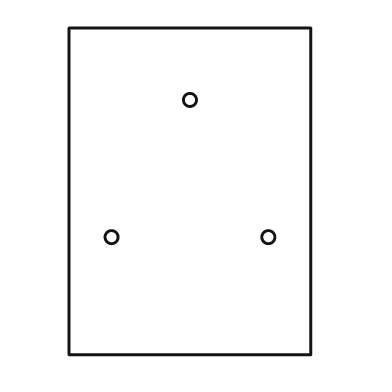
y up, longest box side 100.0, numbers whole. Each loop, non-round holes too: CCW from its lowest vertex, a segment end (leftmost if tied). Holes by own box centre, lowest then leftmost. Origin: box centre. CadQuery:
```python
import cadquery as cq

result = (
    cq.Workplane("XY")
    .moveTo(-37.0, -50.0)
    .lineTo(37.0, -50.0)
    .lineTo(37.0, 50.0)
    .lineTo(-37.0, 50.0)
    .close()
    .moveTo(-24.0, -14.0)
    .circle(2.0)
    .moveTo(24.0, -14.0)
    .circle(2.0)
    .moveTo(0.0, 28.0)
    .circle(2.0)
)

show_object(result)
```